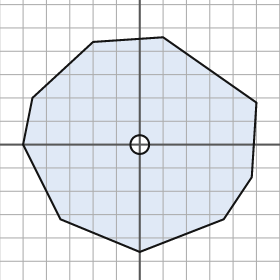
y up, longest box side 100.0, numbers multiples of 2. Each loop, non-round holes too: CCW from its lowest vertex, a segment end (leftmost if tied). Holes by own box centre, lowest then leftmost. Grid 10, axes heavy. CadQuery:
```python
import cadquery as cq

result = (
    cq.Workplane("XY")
    .moveTo(0.0, -46.0)
    .lineTo(36.0, -32.0)
    .lineTo(48.0, -14.0)
    .lineTo(50.0, 18.0)
    .lineTo(10.0, 46.0)
    .lineTo(-20.0, 44.0)
    .lineTo(-46.0, 20.0)
    .lineTo(-50.0, 0.0)
    .lineTo(-34.0, -32.0)
    .close()
    .moveTo(0.0, 0.0)
    .circle(4.0)
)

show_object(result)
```